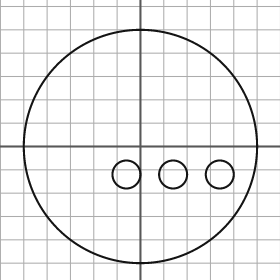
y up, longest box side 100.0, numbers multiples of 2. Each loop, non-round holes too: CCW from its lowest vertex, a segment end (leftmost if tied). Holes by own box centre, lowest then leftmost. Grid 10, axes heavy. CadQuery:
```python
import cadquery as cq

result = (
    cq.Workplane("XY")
    .moveTo(0.0, 0.0)
    .circle(50.0)
    .moveTo(-6.0, -12.0)
    .circle(6.0)
    .moveTo(14.0, -12.0)
    .circle(6.0)
    .moveTo(34.0, -12.0)
    .circle(6.0)
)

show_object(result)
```